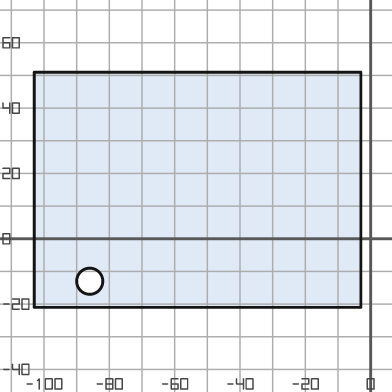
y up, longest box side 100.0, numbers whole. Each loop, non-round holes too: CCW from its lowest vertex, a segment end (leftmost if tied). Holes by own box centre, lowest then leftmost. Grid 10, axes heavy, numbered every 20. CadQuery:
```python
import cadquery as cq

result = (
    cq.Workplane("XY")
    .moveTo(-103.0, -21.0)
    .lineTo(-3.0, -21.0)
    .lineTo(-3.0, 51.0)
    .lineTo(-103.0, 51.0)
    .close()
    .moveTo(-86.0, -13.0)
    .circle(4.0)
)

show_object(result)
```